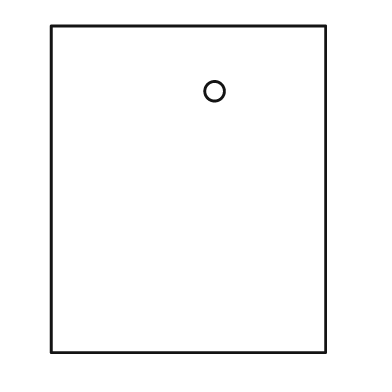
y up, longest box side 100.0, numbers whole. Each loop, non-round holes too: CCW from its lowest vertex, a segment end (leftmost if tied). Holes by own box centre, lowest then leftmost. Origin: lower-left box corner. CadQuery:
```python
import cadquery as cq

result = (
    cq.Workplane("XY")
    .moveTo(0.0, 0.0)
    .lineTo(84.0, 0.0)
    .lineTo(84.0, 100.0)
    .lineTo(0.0, 100.0)
    .close()
    .moveTo(50.0, 80.0)
    .circle(3.0)
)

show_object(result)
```